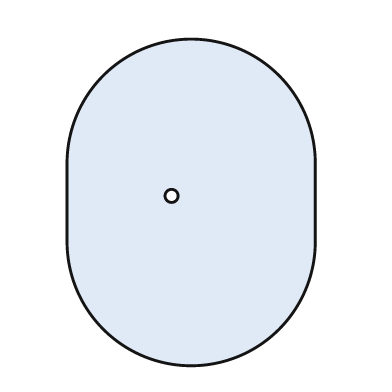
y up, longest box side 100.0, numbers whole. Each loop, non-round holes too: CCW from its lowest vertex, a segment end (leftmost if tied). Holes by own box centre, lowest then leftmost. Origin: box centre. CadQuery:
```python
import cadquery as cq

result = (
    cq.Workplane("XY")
    .moveTo(-38.0, -12.0)
    .threePointArc((0.0, -50.0), (38.0, -12.0))
    .lineTo(38.0, 12.0)
    .threePointArc((0.0, 50.0), (-38.0, 12.0))
    .close()
    .moveTo(-6.0, 2.0)
    .circle(2.0)
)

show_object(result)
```